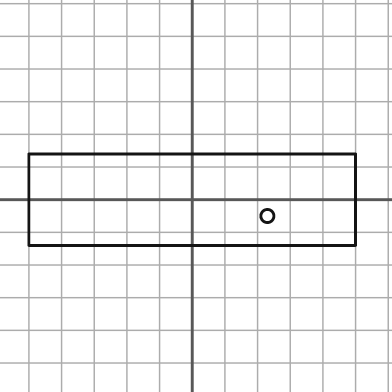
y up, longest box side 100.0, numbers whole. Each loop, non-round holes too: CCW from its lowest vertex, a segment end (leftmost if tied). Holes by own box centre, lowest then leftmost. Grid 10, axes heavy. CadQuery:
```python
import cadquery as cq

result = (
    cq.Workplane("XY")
    .moveTo(-50.0, -14.0)
    .lineTo(50.0, -14.0)
    .lineTo(50.0, 14.0)
    .lineTo(-50.0, 14.0)
    .close()
    .moveTo(23.0, -5.0)
    .circle(2.0)
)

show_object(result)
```